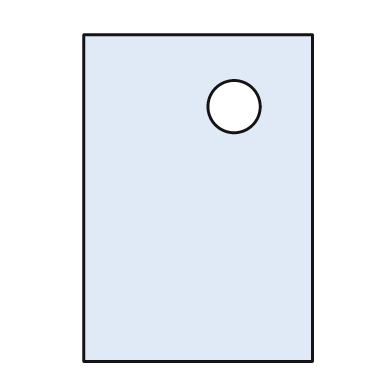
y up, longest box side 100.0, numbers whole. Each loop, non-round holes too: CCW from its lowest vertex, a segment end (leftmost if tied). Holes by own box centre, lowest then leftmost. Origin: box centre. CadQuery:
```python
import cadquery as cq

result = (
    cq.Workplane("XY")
    .moveTo(-35.0, -50.0)
    .lineTo(35.0, -50.0)
    .lineTo(35.0, 50.0)
    .lineTo(-35.0, 50.0)
    .close()
    .moveTo(11.0, 28.0)
    .circle(8.0)
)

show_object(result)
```